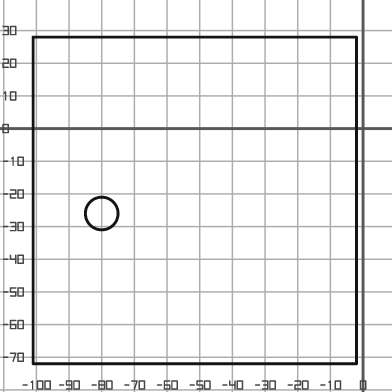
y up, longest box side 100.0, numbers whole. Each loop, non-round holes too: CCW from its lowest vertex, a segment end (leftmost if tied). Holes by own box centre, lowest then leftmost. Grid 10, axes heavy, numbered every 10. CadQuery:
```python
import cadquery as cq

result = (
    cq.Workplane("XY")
    .moveTo(-101.0, -72.0)
    .lineTo(-2.0, -72.0)
    .lineTo(-2.0, 28.0)
    .lineTo(-101.0, 28.0)
    .close()
    .moveTo(-80.0, -26.0)
    .circle(5.0)
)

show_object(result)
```